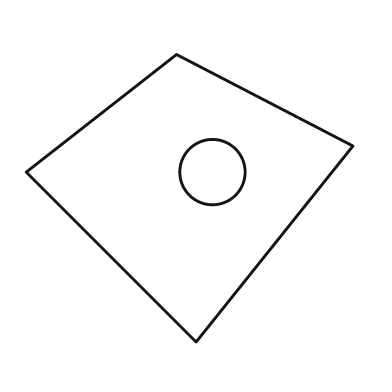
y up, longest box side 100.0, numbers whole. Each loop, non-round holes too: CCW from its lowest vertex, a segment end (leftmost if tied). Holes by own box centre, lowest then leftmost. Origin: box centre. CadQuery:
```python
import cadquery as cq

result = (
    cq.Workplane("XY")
    .moveTo(2.0, -44.0)
    .lineTo(50.0, 16.0)
    .lineTo(-4.0, 44.0)
    .lineTo(-50.0, 8.0)
    .close()
    .moveTo(7.0, 8.0)
    .circle(10.0)
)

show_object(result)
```